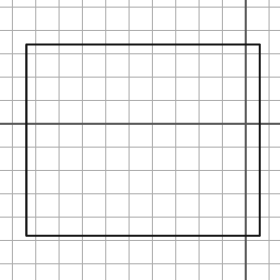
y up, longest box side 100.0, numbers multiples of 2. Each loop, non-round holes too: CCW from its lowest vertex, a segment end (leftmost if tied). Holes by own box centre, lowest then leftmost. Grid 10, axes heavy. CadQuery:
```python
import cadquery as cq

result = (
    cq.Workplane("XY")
    .moveTo(-94.0, -48.0)
    .lineTo(6.0, -48.0)
    .lineTo(6.0, 34.0)
    .lineTo(-94.0, 34.0)
    .close()
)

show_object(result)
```